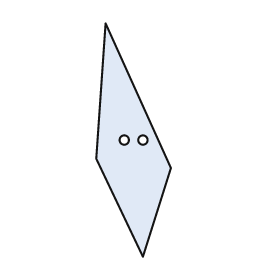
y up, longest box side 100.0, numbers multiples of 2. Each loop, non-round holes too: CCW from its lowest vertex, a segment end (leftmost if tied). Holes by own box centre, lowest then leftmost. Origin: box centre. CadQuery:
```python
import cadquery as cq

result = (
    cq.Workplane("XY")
    .moveTo(4.0, -50.0)
    .lineTo(16.0, -12.0)
    .lineTo(-12.0, 50.0)
    .lineTo(-16.0, -8.0)
    .close()
    .moveTo(-4.0, 0.0)
    .circle(2.0)
    .moveTo(4.0, 0.0)
    .circle(2.0)
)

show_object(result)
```